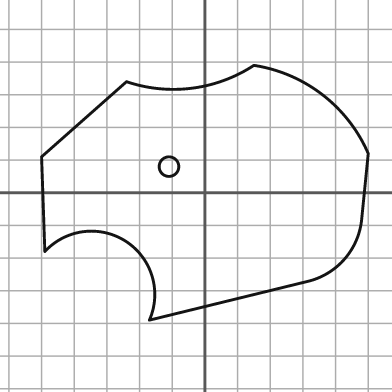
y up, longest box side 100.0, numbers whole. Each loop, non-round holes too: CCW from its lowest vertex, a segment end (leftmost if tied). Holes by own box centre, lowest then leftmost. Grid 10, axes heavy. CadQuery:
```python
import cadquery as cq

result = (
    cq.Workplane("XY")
    .moveTo(-17.0, -39.0)
    .lineTo(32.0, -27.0)
    .threePointArc((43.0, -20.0), (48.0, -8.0))
    .lineTo(50.0, 12.0)
    .threePointArc((36.0, 30.0), (15.0, 39.0))
    .threePointArc((-4.0, 32.0), (-24.0, 34.0))
    .lineTo(-50.0, 11.0)
    .lineTo(-49.0, -18.0)
    .threePointArc((-24.0, -15.0), (-17.0, -39.0))
    .close()
    .moveTo(-11.0, 8.0)
    .circle(3.0)
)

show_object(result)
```